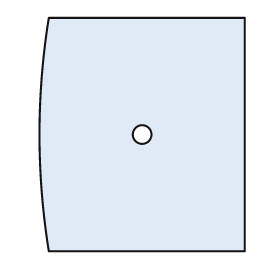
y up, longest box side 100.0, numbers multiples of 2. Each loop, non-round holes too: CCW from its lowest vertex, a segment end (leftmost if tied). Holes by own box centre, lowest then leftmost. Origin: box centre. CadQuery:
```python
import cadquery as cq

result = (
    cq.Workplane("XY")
    .moveTo(-40.0, -50.0)
    .lineTo(44.0, -50.0)
    .lineTo(44.0, 50.0)
    .lineTo(-40.0, 50.0)
    .threePointArc((-44.0, 0.0), (-40.0, -50.0))
    .close()
    .moveTo(0.0, 0.0)
    .circle(4.0)
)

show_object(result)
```